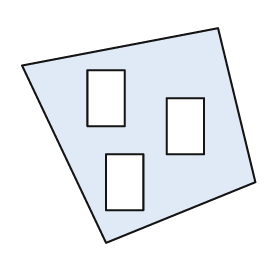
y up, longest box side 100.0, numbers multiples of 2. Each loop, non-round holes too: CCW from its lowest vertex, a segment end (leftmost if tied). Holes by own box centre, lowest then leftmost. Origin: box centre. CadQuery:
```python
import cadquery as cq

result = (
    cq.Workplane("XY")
    .moveTo(-14.0, -46.0)
    .lineTo(50.0, -20.0)
    .lineTo(34.0, 46.0)
    .lineTo(-50.0, 30.0)
    .close()
    .moveTo(-14.0, -32.0)
    .lineTo(2.0, -32.0)
    .lineTo(2.0, -8.0)
    .lineTo(-14.0, -8.0)
    .close()
    .moveTo(12.0, -8.0)
    .lineTo(28.0, -8.0)
    .lineTo(28.0, 16.0)
    .lineTo(12.0, 16.0)
    .close()
    .moveTo(-22.0, 4.0)
    .lineTo(-6.0, 4.0)
    .lineTo(-6.0, 28.0)
    .lineTo(-22.0, 28.0)
    .close()
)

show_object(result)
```